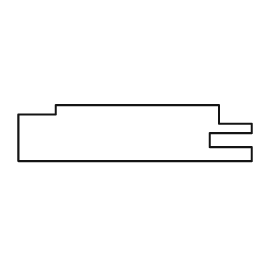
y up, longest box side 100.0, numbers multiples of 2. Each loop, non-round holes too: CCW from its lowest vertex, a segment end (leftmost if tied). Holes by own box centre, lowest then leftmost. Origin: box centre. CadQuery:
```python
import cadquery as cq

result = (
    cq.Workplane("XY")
    .moveTo(-50.0, -12.0)
    .lineTo(50.0, -12.0)
    .lineTo(50.0, -6.0)
    .lineTo(32.0, -6.0)
    .lineTo(32.0, 0.0)
    .lineTo(50.0, 0.0)
    .lineTo(50.0, 4.0)
    .lineTo(36.0, 4.0)
    .lineTo(36.0, 12.0)
    .lineTo(-34.0, 12.0)
    .lineTo(-34.0, 8.0)
    .lineTo(-50.0, 8.0)
    .close()
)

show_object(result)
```